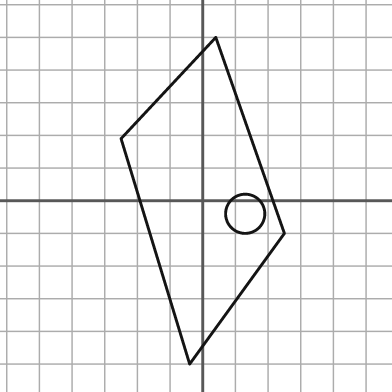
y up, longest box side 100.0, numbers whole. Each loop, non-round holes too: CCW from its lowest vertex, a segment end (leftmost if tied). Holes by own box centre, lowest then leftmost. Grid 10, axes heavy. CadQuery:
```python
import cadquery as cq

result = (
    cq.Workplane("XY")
    .moveTo(-4.0, -50.0)
    .lineTo(25.0, -10.0)
    .lineTo(4.0, 50.0)
    .lineTo(-25.0, 19.0)
    .close()
    .moveTo(13.0, -4.0)
    .circle(6.0)
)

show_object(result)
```